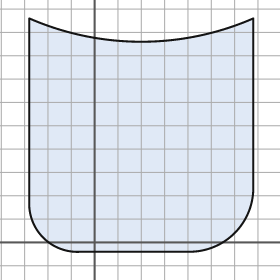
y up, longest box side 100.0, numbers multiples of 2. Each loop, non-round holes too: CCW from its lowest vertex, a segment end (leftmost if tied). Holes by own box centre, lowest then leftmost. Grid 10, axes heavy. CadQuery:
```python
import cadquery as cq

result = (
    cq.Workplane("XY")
    .moveTo(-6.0, -4.0)
    .lineTo(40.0, -4.0)
    .threePointArc((60.0, 4.0), (68.0, 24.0))
    .lineTo(68.0, 96.0)
    .threePointArc((20.0, 86.0), (-28.0, 96.0))
    .lineTo(-28.0, 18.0)
    .threePointArc((-22.0, 2.0), (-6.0, -4.0))
    .close()
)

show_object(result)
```